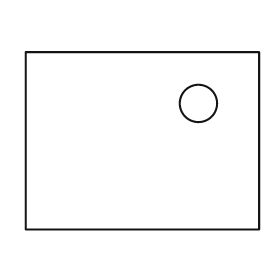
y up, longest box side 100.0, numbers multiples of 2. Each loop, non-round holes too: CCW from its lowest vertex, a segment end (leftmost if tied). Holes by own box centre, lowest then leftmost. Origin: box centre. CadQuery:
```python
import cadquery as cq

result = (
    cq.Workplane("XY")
    .moveTo(-50.0, -38.0)
    .lineTo(50.0, -38.0)
    .lineTo(50.0, 38.0)
    .lineTo(-50.0, 38.0)
    .close()
    .moveTo(24.0, 16.0)
    .circle(8.0)
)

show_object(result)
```